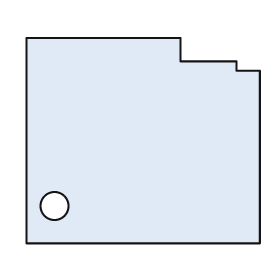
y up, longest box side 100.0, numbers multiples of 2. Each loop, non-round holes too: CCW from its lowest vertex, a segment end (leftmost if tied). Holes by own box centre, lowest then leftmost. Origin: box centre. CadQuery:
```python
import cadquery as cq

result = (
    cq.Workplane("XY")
    .moveTo(-50.0, -44.0)
    .lineTo(50.0, -44.0)
    .lineTo(50.0, 30.0)
    .lineTo(40.0, 30.0)
    .lineTo(40.0, 34.0)
    .lineTo(16.0, 34.0)
    .lineTo(16.0, 44.0)
    .lineTo(-50.0, 44.0)
    .close()
    .moveTo(-38.0, -28.0)
    .circle(6.0)
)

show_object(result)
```